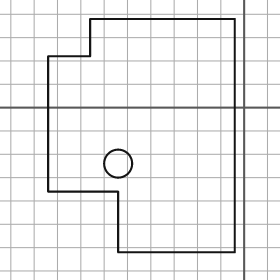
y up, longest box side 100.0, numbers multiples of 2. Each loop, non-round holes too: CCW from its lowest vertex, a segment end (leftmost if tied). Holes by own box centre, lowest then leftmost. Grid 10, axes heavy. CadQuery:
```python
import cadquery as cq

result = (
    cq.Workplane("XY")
    .moveTo(-54.0, -62.0)
    .lineTo(-4.0, -62.0)
    .lineTo(-4.0, 38.0)
    .lineTo(-66.0, 38.0)
    .lineTo(-66.0, 22.0)
    .lineTo(-84.0, 22.0)
    .lineTo(-84.0, -36.0)
    .lineTo(-54.0, -36.0)
    .close()
    .moveTo(-54.0, -24.0)
    .circle(6.0)
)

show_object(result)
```